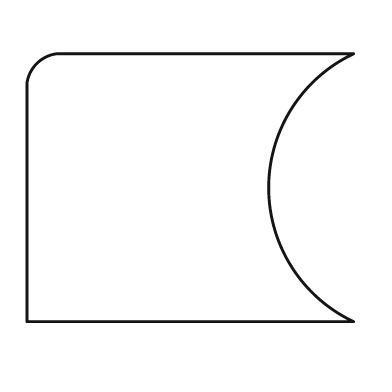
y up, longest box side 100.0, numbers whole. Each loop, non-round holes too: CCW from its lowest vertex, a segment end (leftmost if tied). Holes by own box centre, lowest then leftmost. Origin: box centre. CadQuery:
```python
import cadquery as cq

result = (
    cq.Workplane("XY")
    .moveTo(-50.0, -41.0)
    .lineTo(50.0, -41.0)
    .threePointArc((24.0, 0.0), (50.0, 41.0))
    .lineTo(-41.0, 41.0)
    .threePointArc((-47.0, 38.0), (-50.0, 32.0))
    .close()
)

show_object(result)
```